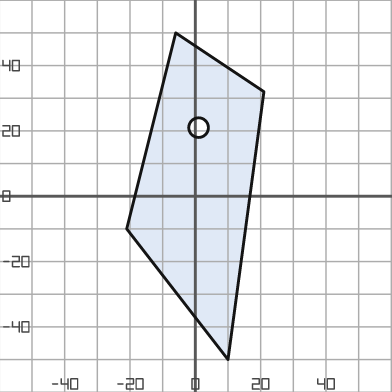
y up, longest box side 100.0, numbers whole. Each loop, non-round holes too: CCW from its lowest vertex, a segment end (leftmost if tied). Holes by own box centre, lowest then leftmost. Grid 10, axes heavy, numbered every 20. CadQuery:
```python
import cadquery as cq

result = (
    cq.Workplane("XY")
    .moveTo(10.0, -50.0)
    .lineTo(21.0, 32.0)
    .lineTo(-6.0, 50.0)
    .lineTo(-21.0, -10.0)
    .close()
    .moveTo(1.0, 21.0)
    .circle(3.0)
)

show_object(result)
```